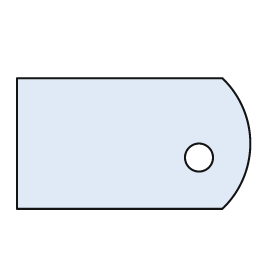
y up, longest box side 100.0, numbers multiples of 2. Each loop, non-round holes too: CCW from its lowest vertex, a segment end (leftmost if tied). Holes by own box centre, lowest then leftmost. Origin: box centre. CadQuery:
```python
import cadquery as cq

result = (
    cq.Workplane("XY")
    .moveTo(-50.0, -28.0)
    .lineTo(38.0, -28.0)
    .threePointArc((50.0, 0.0), (38.0, 28.0))
    .lineTo(-50.0, 28.0)
    .close()
    .moveTo(28.0, -6.0)
    .circle(6.0)
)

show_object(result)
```